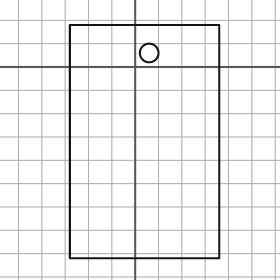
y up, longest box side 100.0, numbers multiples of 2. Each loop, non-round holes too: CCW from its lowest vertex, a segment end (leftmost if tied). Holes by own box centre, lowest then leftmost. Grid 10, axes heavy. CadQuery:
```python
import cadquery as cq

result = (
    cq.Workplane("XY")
    .moveTo(-28.0, -82.0)
    .lineTo(36.0, -82.0)
    .lineTo(36.0, 18.0)
    .lineTo(-28.0, 18.0)
    .close()
    .moveTo(6.0, 6.0)
    .circle(4.0)
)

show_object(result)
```